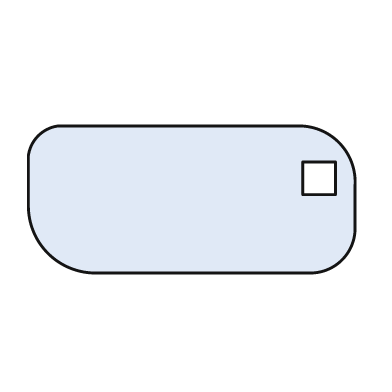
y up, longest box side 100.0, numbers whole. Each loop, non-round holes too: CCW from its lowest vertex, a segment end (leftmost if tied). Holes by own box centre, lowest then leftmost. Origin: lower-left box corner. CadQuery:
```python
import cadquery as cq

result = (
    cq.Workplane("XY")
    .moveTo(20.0, 0.0)
    .lineTo(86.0, 0.0)
    .threePointArc((96.0, 4.0), (100.0, 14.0))
    .lineTo(100.0, 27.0)
    .threePointArc((95.0, 40.0), (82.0, 45.0))
    .lineTo(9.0, 45.0)
    .threePointArc((3.0, 42.0), (0.0, 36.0))
    .lineTo(0.0, 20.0)
    .threePointArc((6.0, 6.0), (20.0, 0.0))
    .close()
    .moveTo(84.0, 24.0)
    .lineTo(94.0, 24.0)
    .lineTo(94.0, 34.0)
    .lineTo(84.0, 34.0)
    .close()
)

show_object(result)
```